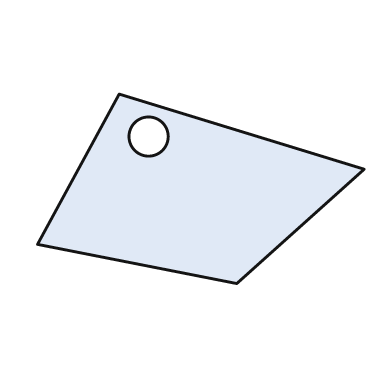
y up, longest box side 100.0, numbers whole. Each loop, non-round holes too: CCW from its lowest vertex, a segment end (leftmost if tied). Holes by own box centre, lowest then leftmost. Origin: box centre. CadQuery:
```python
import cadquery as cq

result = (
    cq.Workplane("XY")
    .moveTo(11.0, -29.0)
    .lineTo(50.0, 6.0)
    .lineTo(-25.0, 29.0)
    .lineTo(-50.0, -17.0)
    .close()
    .moveTo(-16.0, 16.0)
    .circle(6.0)
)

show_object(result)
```